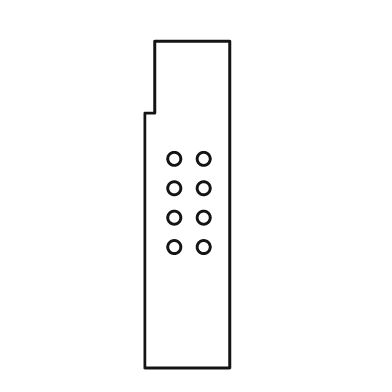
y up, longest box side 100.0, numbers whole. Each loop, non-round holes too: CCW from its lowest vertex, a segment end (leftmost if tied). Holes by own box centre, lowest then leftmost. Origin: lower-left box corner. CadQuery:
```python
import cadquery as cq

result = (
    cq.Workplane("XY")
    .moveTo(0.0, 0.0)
    .lineTo(26.0, 0.0)
    .lineTo(26.0, 100.0)
    .lineTo(3.0, 100.0)
    .lineTo(3.0, 78.0)
    .lineTo(0.0, 78.0)
    .close()
    .moveTo(9.0, 37.0)
    .circle(2.0)
    .moveTo(18.0, 37.0)
    .circle(2.0)
    .moveTo(9.0, 46.0)
    .circle(2.0)
    .moveTo(18.0, 46.0)
    .circle(2.0)
    .moveTo(9.0, 55.0)
    .circle(2.0)
    .moveTo(18.0, 55.0)
    .circle(2.0)
    .moveTo(9.0, 64.0)
    .circle(2.0)
    .moveTo(18.0, 64.0)
    .circle(2.0)
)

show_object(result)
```